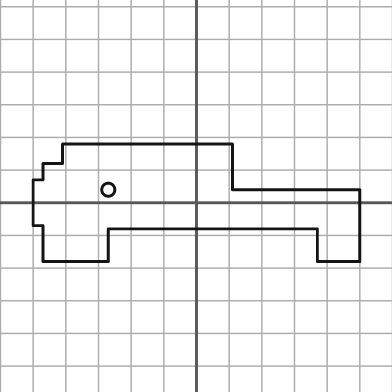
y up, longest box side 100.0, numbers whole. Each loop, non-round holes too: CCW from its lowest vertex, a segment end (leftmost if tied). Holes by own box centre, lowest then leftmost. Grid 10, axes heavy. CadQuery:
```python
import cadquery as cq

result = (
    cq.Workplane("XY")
    .moveTo(-47.0, -18.0)
    .lineTo(-27.0, -18.0)
    .lineTo(-27.0, -8.0)
    .lineTo(37.0, -8.0)
    .lineTo(37.0, -18.0)
    .lineTo(50.0, -18.0)
    .lineTo(50.0, 4.0)
    .lineTo(11.0, 4.0)
    .lineTo(11.0, 18.0)
    .lineTo(-41.0, 18.0)
    .lineTo(-41.0, 12.0)
    .lineTo(-47.0, 12.0)
    .lineTo(-47.0, 7.0)
    .lineTo(-50.0, 7.0)
    .lineTo(-50.0, -7.0)
    .lineTo(-47.0, -7.0)
    .close()
    .moveTo(-27.0, 4.0)
    .circle(2.0)
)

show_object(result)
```